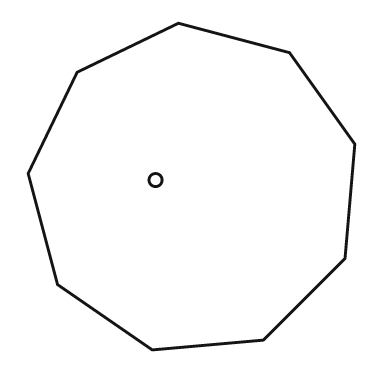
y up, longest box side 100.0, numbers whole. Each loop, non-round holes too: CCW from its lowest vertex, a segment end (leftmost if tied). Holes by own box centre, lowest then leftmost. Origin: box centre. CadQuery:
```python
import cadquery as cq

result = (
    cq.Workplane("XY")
    .moveTo(-12.0, -50.0)
    .lineTo(22.0, -47.0)
    .lineTo(47.0, -22.0)
    .lineTo(50.0, 13.0)
    .lineTo(30.0, 41.0)
    .lineTo(-4.0, 50.0)
    .lineTo(-35.0, 35.0)
    .lineTo(-50.0, 4.0)
    .lineTo(-41.0, -30.0)
    .close()
    .moveTo(-11.0, 2.0)
    .circle(2.0)
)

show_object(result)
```